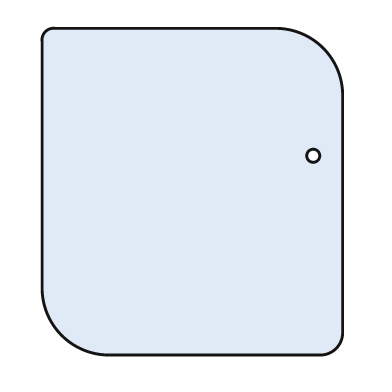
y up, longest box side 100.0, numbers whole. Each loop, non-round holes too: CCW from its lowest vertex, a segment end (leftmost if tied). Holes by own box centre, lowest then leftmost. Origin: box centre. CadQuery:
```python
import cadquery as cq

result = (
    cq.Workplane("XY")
    .moveTo(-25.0, -50.0)
    .lineTo(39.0, -50.0)
    .threePointArc((44.0, -48.0), (46.0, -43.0))
    .lineTo(46.0, 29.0)
    .threePointArc((40.0, 44.0), (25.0, 50.0))
    .lineTo(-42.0, 50.0)
    .threePointArc((-45.0, 49.0), (-46.0, 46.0))
    .lineTo(-46.0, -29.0)
    .threePointArc((-40.0, -44.0), (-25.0, -50.0))
    .close()
    .moveTo(37.0, 11.0)
    .circle(2.0)
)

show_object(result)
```